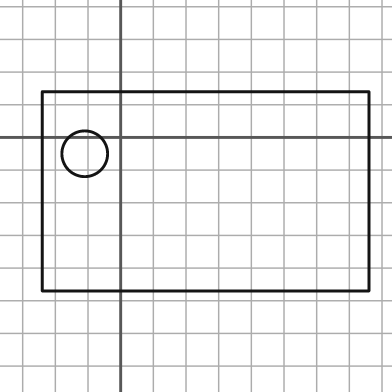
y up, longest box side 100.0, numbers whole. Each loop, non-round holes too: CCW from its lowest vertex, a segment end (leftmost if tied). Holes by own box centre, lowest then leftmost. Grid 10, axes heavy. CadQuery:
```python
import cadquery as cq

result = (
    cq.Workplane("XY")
    .moveTo(-24.0, -47.0)
    .lineTo(76.0, -47.0)
    .lineTo(76.0, 14.0)
    .lineTo(-24.0, 14.0)
    .close()
    .moveTo(-11.0, -5.0)
    .circle(7.0)
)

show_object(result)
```